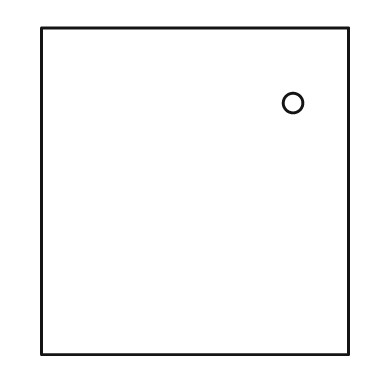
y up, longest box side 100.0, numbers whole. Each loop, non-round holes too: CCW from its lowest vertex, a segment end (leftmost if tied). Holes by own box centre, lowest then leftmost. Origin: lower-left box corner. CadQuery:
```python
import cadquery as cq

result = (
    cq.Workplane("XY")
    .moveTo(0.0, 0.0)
    .lineTo(94.0, 0.0)
    .lineTo(94.0, 100.0)
    .lineTo(0.0, 100.0)
    .close()
    .moveTo(77.0, 77.0)
    .circle(3.0)
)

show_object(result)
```